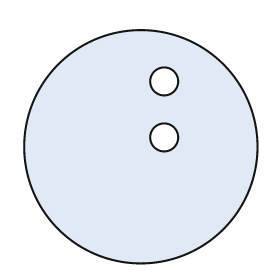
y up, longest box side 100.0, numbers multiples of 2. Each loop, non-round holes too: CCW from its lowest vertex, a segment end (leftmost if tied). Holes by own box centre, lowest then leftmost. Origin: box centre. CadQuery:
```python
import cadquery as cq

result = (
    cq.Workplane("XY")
    .moveTo(0.0, 0.0)
    .circle(50.0)
    .moveTo(10.0, 4.0)
    .circle(6.0)
    .moveTo(10.0, 28.0)
    .circle(6.0)
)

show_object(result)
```